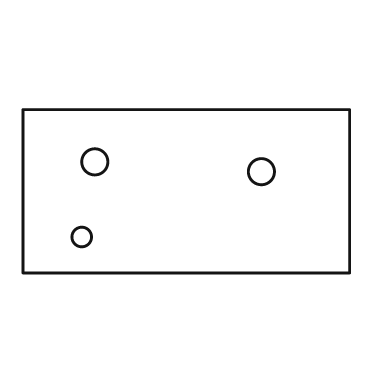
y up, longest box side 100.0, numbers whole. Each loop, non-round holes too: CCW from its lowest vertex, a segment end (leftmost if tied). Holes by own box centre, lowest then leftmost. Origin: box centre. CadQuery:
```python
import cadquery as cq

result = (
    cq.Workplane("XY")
    .moveTo(-50.0, -25.0)
    .lineTo(50.0, -25.0)
    .lineTo(50.0, 25.0)
    .lineTo(-50.0, 25.0)
    .close()
    .moveTo(-32.0, -14.0)
    .circle(3.0)
    .moveTo(23.0, 6.0)
    .circle(4.0)
    .moveTo(-28.0, 9.0)
    .circle(4.0)
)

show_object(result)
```